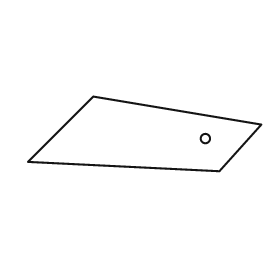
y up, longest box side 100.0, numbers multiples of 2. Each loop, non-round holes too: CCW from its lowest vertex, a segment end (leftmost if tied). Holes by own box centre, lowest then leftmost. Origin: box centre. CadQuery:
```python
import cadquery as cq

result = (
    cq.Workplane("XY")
    .moveTo(32.0, -16.0)
    .lineTo(50.0, 4.0)
    .lineTo(-22.0, 16.0)
    .lineTo(-50.0, -12.0)
    .close()
    .moveTo(26.0, -2.0)
    .circle(2.0)
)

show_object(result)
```